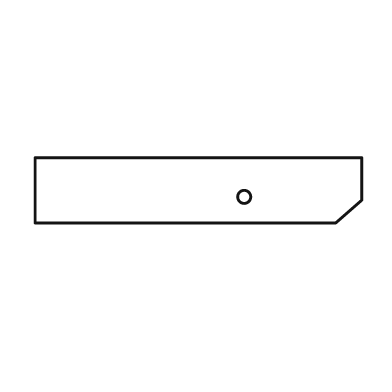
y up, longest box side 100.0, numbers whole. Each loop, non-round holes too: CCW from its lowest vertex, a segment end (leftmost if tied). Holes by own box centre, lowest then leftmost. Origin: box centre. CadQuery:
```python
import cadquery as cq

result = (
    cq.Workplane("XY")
    .moveTo(-50.0, -10.0)
    .lineTo(42.0, -10.0)
    .lineTo(50.0, -3.0)
    .lineTo(50.0, 10.0)
    .lineTo(-50.0, 10.0)
    .close()
    .moveTo(14.0, -2.0)
    .circle(2.0)
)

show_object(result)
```